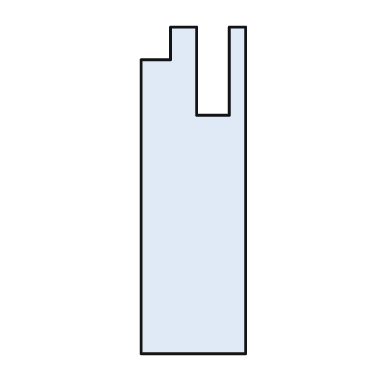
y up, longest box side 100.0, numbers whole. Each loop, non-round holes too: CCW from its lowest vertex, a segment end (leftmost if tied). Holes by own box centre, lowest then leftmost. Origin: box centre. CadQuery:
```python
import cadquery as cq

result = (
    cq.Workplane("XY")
    .moveTo(-16.0, -50.0)
    .lineTo(16.0, -50.0)
    .lineTo(16.0, 50.0)
    .lineTo(11.0, 50.0)
    .lineTo(11.0, 23.0)
    .lineTo(1.0, 23.0)
    .lineTo(1.0, 50.0)
    .lineTo(-7.0, 50.0)
    .lineTo(-7.0, 40.0)
    .lineTo(-16.0, 40.0)
    .close()
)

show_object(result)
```